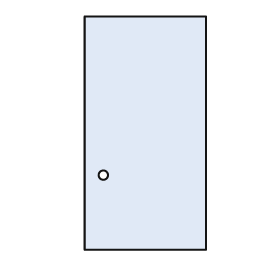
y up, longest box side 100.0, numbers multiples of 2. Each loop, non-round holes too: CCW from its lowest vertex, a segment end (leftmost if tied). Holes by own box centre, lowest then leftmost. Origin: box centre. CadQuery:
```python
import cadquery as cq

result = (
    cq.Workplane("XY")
    .moveTo(-26.0, -50.0)
    .lineTo(26.0, -50.0)
    .lineTo(26.0, 50.0)
    .lineTo(-26.0, 50.0)
    .close()
    .moveTo(-18.0, -18.0)
    .circle(2.0)
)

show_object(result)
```